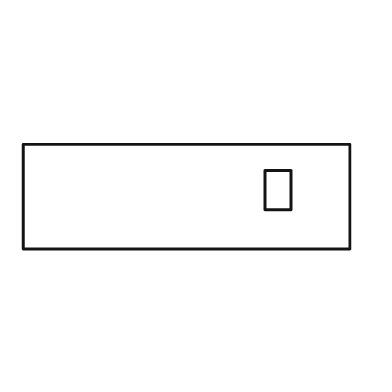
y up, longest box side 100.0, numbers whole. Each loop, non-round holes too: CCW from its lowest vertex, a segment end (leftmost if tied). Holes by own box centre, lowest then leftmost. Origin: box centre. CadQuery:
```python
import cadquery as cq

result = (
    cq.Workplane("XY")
    .moveTo(-50.0, -16.0)
    .lineTo(50.0, -16.0)
    .lineTo(50.0, 16.0)
    .lineTo(-50.0, 16.0)
    .close()
    .moveTo(24.0, -4.0)
    .lineTo(32.0, -4.0)
    .lineTo(32.0, 8.0)
    .lineTo(24.0, 8.0)
    .close()
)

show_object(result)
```